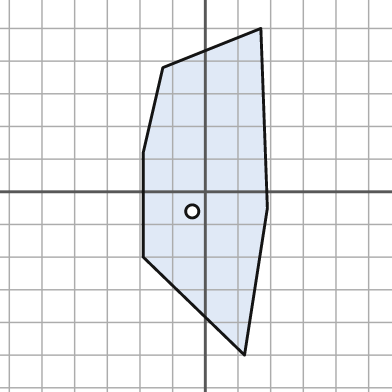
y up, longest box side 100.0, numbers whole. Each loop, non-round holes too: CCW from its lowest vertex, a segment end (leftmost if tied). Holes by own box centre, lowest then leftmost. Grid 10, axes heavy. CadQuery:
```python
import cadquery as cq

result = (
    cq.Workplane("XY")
    .moveTo(12.0, -50.0)
    .lineTo(19.0, -5.0)
    .lineTo(17.0, 50.0)
    .lineTo(-13.0, 38.0)
    .lineTo(-19.0, 12.0)
    .lineTo(-19.0, -20.0)
    .close()
    .moveTo(-4.0, -6.0)
    .circle(2.0)
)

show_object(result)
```